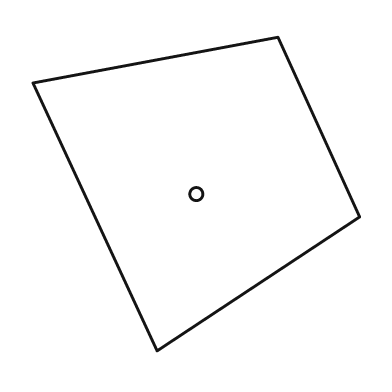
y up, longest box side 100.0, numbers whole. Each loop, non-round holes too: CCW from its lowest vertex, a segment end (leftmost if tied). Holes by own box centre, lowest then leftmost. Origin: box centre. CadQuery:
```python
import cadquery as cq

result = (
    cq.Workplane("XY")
    .moveTo(-12.0, -48.0)
    .lineTo(50.0, -7.0)
    .lineTo(25.0, 48.0)
    .lineTo(-50.0, 34.0)
    .close()
    .moveTo(0.0, 0.0)
    .circle(2.0)
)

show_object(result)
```